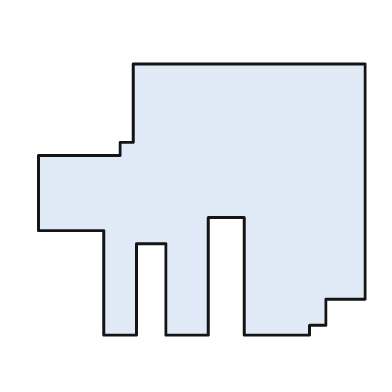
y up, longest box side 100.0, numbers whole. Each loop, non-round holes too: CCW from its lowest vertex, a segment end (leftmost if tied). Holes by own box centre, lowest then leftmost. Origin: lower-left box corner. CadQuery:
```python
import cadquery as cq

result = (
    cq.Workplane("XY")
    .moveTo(20.0, 0.0)
    .lineTo(30.0, 0.0)
    .lineTo(30.0, 28.0)
    .lineTo(39.0, 28.0)
    .lineTo(39.0, 0.0)
    .lineTo(52.0, 0.0)
    .lineTo(52.0, 36.0)
    .lineTo(63.0, 36.0)
    .lineTo(63.0, 0.0)
    .lineTo(83.0, 0.0)
    .lineTo(83.0, 3.0)
    .lineTo(88.0, 3.0)
    .lineTo(88.0, 11.0)
    .lineTo(100.0, 11.0)
    .lineTo(100.0, 83.0)
    .lineTo(29.0, 83.0)
    .lineTo(29.0, 59.0)
    .lineTo(25.0, 59.0)
    .lineTo(25.0, 55.0)
    .lineTo(0.0, 55.0)
    .lineTo(0.0, 32.0)
    .lineTo(20.0, 32.0)
    .close()
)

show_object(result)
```